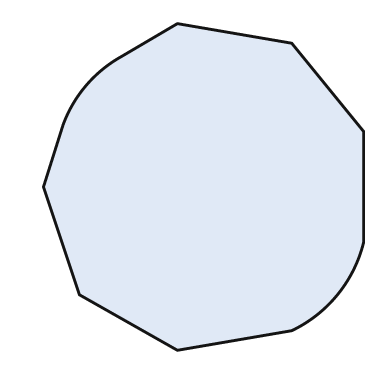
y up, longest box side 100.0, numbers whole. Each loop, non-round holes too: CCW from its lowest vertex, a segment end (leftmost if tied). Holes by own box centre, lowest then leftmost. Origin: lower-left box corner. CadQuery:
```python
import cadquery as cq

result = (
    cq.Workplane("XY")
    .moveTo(41.0, 0.0)
    .lineTo(76.0, 6.0)
    .threePointArc((90.0, 17.0), (98.0, 33.0))
    .lineTo(98.0, 67.0)
    .lineTo(76.0, 94.0)
    .lineTo(41.0, 100.0)
    .lineTo(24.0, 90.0)
    .threePointArc((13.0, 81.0), (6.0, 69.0))
    .lineTo(0.0, 50.0)
    .lineTo(11.0, 17.0)
    .close()
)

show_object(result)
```